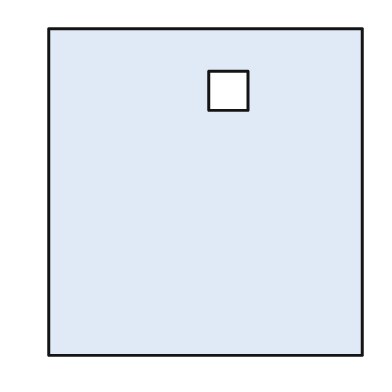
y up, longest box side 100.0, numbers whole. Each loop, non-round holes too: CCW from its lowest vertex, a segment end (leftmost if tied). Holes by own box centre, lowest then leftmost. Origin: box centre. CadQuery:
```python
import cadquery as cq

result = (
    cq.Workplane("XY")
    .moveTo(-48.0, -50.0)
    .lineTo(48.0, -50.0)
    .lineTo(48.0, 50.0)
    .lineTo(-48.0, 50.0)
    .close()
    .moveTo(1.0, 25.0)
    .lineTo(13.0, 25.0)
    .lineTo(13.0, 37.0)
    .lineTo(1.0, 37.0)
    .close()
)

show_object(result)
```